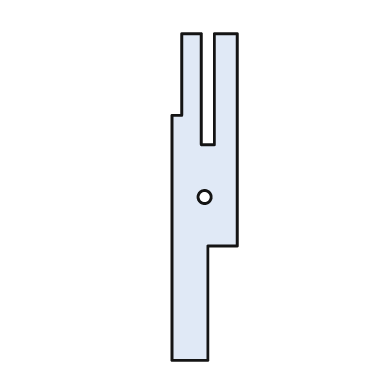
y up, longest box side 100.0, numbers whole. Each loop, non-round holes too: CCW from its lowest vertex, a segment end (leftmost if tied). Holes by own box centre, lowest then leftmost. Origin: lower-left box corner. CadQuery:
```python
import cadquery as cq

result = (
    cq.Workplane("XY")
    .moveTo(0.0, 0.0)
    .lineTo(11.0, 0.0)
    .lineTo(11.0, 35.0)
    .lineTo(20.0, 35.0)
    .lineTo(20.0, 100.0)
    .lineTo(13.0, 100.0)
    .lineTo(13.0, 66.0)
    .lineTo(9.0, 66.0)
    .lineTo(9.0, 100.0)
    .lineTo(3.0, 100.0)
    .lineTo(3.0, 75.0)
    .lineTo(0.0, 75.0)
    .close()
    .moveTo(10.0, 50.0)
    .circle(2.0)
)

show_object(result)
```